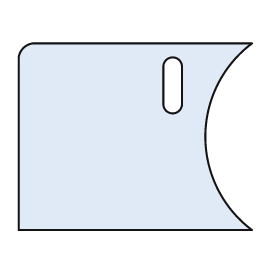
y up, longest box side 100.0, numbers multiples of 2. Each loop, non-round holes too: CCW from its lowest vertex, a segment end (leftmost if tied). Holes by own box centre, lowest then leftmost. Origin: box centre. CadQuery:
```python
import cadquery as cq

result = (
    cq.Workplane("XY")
    .moveTo(-50.0, -40.0)
    .lineTo(50.0, -40.0)
    .threePointArc((30.0, 0.0), (50.0, 40.0))
    .lineTo(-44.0, 40.0)
    .threePointArc((-48.0, 38.0), (-50.0, 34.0))
    .close()
    .moveTo(12.0, 14.0)
    .threePointArc((16.0, 10.0), (20.0, 14.0))
    .lineTo(20.0, 30.0)
    .threePointArc((16.0, 34.0), (12.0, 30.0))
    .close()
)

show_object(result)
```